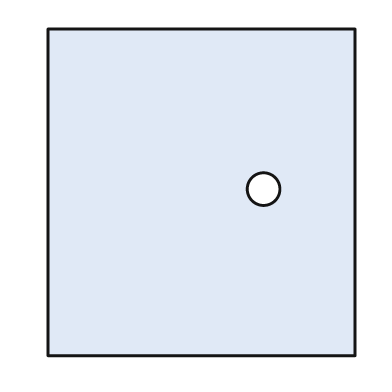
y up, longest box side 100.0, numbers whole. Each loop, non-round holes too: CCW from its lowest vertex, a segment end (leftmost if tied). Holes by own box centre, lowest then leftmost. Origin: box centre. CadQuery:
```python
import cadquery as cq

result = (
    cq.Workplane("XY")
    .moveTo(-47.0, -50.0)
    .lineTo(47.0, -50.0)
    .lineTo(47.0, 50.0)
    .lineTo(-47.0, 50.0)
    .close()
    .moveTo(19.0, 1.0)
    .circle(5.0)
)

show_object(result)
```